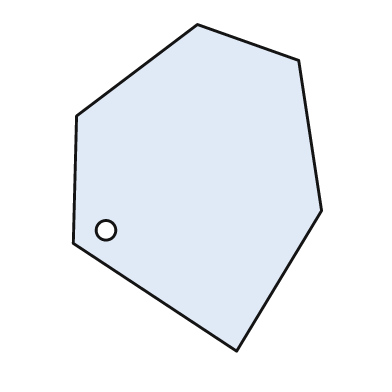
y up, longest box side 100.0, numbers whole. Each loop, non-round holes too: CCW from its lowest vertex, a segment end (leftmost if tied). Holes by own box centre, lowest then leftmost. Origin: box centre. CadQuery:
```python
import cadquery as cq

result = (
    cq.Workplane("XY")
    .moveTo(12.0, -50.0)
    .lineTo(38.0, -7.0)
    .lineTo(31.0, 39.0)
    .lineTo(0.0, 50.0)
    .lineTo(-37.0, 22.0)
    .lineTo(-38.0, -17.0)
    .close()
    .moveTo(-28.0, -13.0)
    .circle(3.0)
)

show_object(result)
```